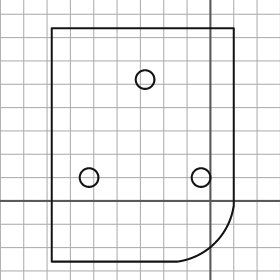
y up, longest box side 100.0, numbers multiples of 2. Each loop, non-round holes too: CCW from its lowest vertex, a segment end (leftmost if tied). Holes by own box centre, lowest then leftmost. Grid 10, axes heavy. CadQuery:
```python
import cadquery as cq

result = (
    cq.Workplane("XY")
    .moveTo(-68.0, -26.0)
    .lineTo(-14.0, -26.0)
    .threePointArc((2.0, -18.0), (10.0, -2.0))
    .lineTo(10.0, 74.0)
    .lineTo(-68.0, 74.0)
    .close()
    .moveTo(-52.0, 10.0)
    .circle(4.0)
    .moveTo(-4.0, 10.0)
    .circle(4.0)
    .moveTo(-28.0, 52.0)
    .circle(4.0)
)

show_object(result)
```